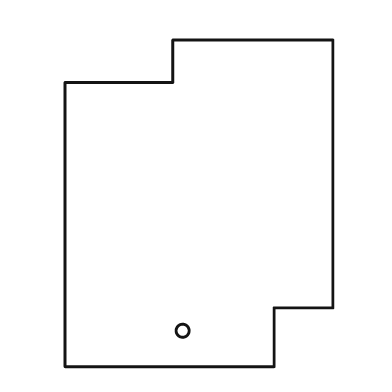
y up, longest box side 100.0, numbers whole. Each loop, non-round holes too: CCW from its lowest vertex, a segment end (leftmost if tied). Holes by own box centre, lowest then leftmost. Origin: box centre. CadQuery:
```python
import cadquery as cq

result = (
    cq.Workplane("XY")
    .moveTo(-41.0, -50.0)
    .lineTo(23.0, -50.0)
    .lineTo(23.0, -32.0)
    .lineTo(41.0, -32.0)
    .lineTo(41.0, 50.0)
    .lineTo(-8.0, 50.0)
    .lineTo(-8.0, 37.0)
    .lineTo(-41.0, 37.0)
    .close()
    .moveTo(-5.0, -39.0)
    .circle(2.0)
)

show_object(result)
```